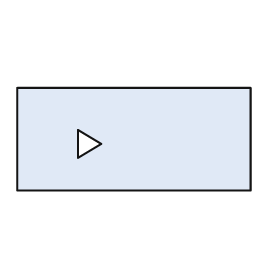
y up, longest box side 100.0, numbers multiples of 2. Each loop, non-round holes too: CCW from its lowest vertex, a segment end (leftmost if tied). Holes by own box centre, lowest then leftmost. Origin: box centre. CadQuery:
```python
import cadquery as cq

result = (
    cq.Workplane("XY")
    .moveTo(-50.0, -22.0)
    .lineTo(50.0, -22.0)
    .lineTo(50.0, 22.0)
    .lineTo(-50.0, 22.0)
    .close()
    .moveTo(-24.0, -8.0)
    .lineTo(-14.0, -2.0)
    .lineTo(-24.0, 4.0)
    .close()
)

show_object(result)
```